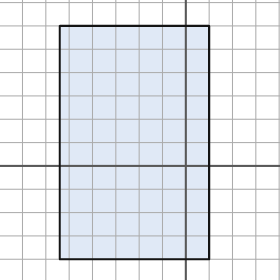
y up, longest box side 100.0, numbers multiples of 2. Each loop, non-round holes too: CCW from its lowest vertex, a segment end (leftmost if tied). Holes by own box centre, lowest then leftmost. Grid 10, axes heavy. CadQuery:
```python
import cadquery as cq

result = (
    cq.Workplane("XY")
    .moveTo(-54.0, -40.0)
    .lineTo(10.0, -40.0)
    .lineTo(10.0, 60.0)
    .lineTo(-54.0, 60.0)
    .close()
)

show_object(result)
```